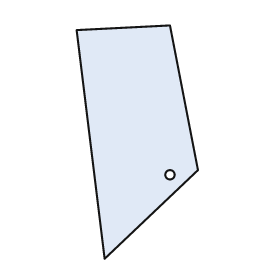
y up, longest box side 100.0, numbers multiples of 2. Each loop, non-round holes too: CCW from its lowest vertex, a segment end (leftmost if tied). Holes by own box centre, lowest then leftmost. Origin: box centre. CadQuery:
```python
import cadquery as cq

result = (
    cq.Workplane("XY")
    .moveTo(-14.0, -50.0)
    .lineTo(26.0, -12.0)
    .lineTo(14.0, 50.0)
    .lineTo(-26.0, 48.0)
    .close()
    .moveTo(14.0, -14.0)
    .circle(2.0)
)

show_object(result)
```